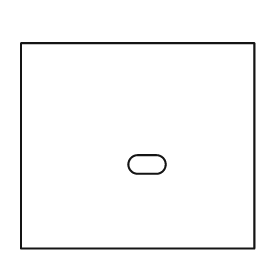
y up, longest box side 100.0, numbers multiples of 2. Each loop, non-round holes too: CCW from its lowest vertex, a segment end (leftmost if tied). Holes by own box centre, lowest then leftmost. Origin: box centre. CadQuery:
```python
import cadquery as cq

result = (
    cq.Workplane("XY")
    .moveTo(-50.0, -44.0)
    .lineTo(50.0, -44.0)
    .lineTo(50.0, 44.0)
    .lineTo(-50.0, 44.0)
    .close()
    .moveTo(0.0, -12.0)
    .lineTo(8.0, -12.0)
    .threePointArc((12.0, -8.0), (8.0, -4.0))
    .lineTo(0.0, -4.0)
    .threePointArc((-4.0, -8.0), (0.0, -12.0))
    .close()
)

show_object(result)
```